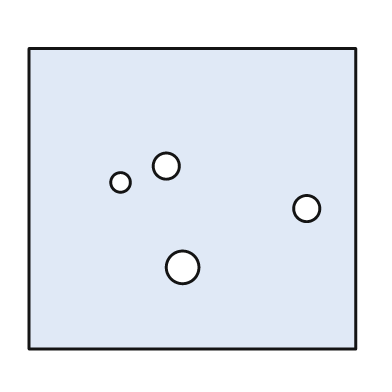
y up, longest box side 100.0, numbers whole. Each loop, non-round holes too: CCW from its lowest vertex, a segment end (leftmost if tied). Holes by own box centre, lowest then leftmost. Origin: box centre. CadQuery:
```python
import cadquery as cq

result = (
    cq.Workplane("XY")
    .moveTo(-50.0, -46.0)
    .lineTo(50.0, -46.0)
    .lineTo(50.0, 46.0)
    .lineTo(-50.0, 46.0)
    .close()
    .moveTo(-3.0, -21.0)
    .circle(5.0)
    .moveTo(35.0, -3.0)
    .circle(4.0)
    .moveTo(-22.0, 5.0)
    .circle(3.0)
    .moveTo(-8.0, 10.0)
    .circle(4.0)
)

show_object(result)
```